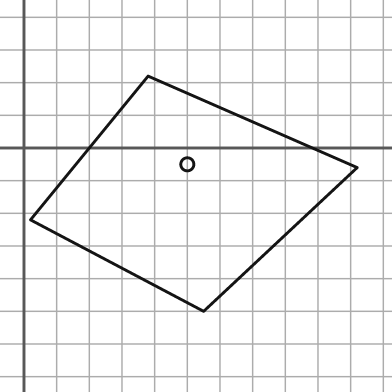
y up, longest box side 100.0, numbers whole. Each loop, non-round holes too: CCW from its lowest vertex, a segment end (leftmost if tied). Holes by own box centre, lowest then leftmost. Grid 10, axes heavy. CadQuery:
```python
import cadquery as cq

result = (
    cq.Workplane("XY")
    .moveTo(55.0, -50.0)
    .lineTo(102.0, -6.0)
    .lineTo(38.0, 22.0)
    .lineTo(2.0, -22.0)
    .close()
    .moveTo(50.0, -5.0)
    .circle(2.0)
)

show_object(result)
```